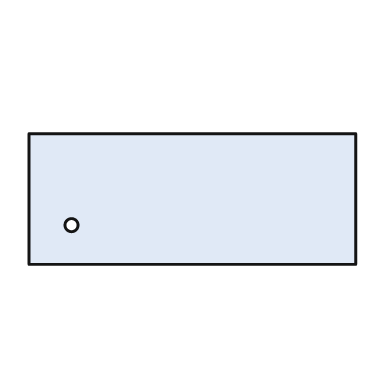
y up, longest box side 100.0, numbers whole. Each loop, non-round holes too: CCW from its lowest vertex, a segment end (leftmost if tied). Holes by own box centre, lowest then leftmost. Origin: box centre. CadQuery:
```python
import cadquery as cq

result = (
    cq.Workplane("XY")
    .moveTo(-50.0, -20.0)
    .lineTo(50.0, -20.0)
    .lineTo(50.0, 20.0)
    .lineTo(-50.0, 20.0)
    .close()
    .moveTo(-37.0, -8.0)
    .circle(2.0)
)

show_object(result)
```